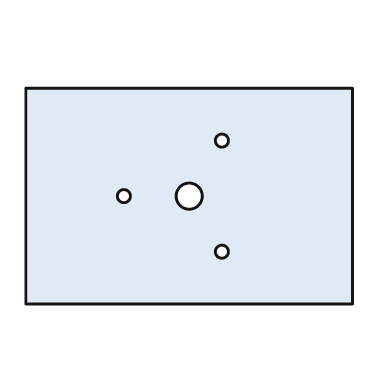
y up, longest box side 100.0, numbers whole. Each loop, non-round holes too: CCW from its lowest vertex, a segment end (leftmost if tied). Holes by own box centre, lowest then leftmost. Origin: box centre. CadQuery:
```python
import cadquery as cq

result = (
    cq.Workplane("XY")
    .moveTo(-50.0, -33.0)
    .lineTo(50.0, -33.0)
    .lineTo(50.0, 33.0)
    .lineTo(-50.0, 33.0)
    .close()
    .moveTo(10.0, -17.0)
    .circle(2.0)
    .moveTo(-20.0, 0.0)
    .circle(2.0)
    .moveTo(0.0, 0.0)
    .circle(4.0)
    .moveTo(10.0, 17.0)
    .circle(2.0)
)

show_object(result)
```